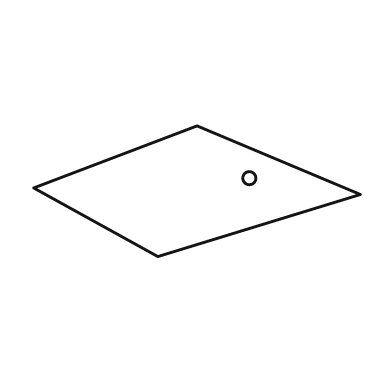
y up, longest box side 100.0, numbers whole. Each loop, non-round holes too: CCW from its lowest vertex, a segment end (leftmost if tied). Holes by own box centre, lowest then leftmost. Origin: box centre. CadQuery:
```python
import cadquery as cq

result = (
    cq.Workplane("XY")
    .moveTo(-12.0, -20.0)
    .lineTo(50.0, -1.0)
    .lineTo(0.0, 20.0)
    .lineTo(-50.0, 1.0)
    .close()
    .moveTo(16.0, 4.0)
    .circle(2.0)
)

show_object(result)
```